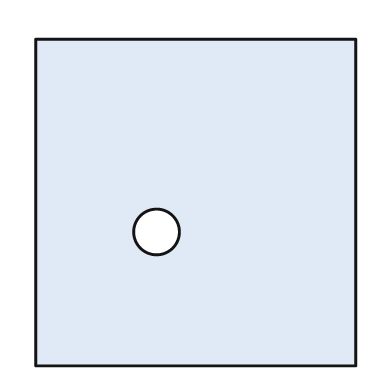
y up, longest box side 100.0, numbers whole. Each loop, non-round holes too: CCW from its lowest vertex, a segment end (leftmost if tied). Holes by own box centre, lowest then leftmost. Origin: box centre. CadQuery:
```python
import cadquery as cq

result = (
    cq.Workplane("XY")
    .moveTo(-49.0, -50.0)
    .lineTo(49.0, -50.0)
    .lineTo(49.0, 50.0)
    .lineTo(-49.0, 50.0)
    .close()
    .moveTo(-12.0, -9.0)
    .circle(7.0)
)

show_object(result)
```